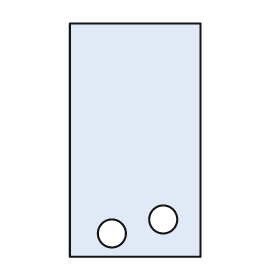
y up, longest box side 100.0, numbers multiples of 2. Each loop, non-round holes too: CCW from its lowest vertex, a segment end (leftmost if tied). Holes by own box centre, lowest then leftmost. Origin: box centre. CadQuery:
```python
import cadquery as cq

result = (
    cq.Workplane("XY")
    .moveTo(-28.0, -50.0)
    .lineTo(28.0, -50.0)
    .lineTo(28.0, 50.0)
    .lineTo(-28.0, 50.0)
    .close()
    .moveTo(-10.0, -40.0)
    .circle(6.0)
    .moveTo(12.0, -34.0)
    .circle(6.0)
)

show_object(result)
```